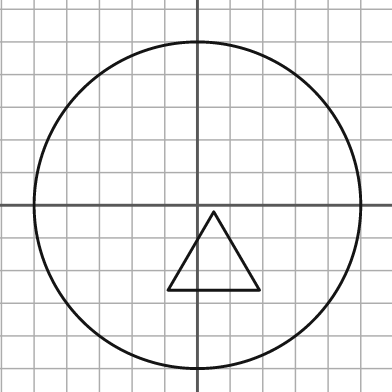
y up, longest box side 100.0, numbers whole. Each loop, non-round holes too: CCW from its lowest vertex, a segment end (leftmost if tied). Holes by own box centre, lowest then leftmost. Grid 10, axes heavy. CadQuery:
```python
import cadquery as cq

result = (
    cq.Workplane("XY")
    .moveTo(0.0, 0.0)
    .circle(50.0)
    .moveTo(-9.0, -26.0)
    .lineTo(19.0, -26.0)
    .lineTo(5.0, -2.0)
    .close()
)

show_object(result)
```